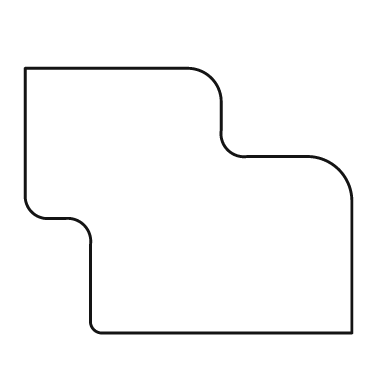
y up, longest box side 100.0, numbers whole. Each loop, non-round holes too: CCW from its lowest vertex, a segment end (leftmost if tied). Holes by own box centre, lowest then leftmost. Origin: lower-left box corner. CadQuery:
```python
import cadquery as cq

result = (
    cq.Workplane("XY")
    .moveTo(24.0, 0.0)
    .lineTo(100.0, 0.0)
    .lineTo(100.0, 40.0)
    .threePointArc((96.0, 50.0), (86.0, 54.0))
    .lineTo(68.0, 54.0)
    .threePointArc((62.0, 56.0), (60.0, 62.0))
    .lineTo(60.0, 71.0)
    .threePointArc((57.0, 78.0), (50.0, 81.0))
    .lineTo(0.0, 81.0)
    .lineTo(0.0, 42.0)
    .threePointArc((2.0, 37.0), (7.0, 35.0))
    .lineTo(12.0, 35.0)
    .threePointArc((18.0, 33.0), (20.0, 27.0))
    .lineTo(20.0, 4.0)
    .threePointArc((21.0, 1.0), (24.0, 0.0))
    .close()
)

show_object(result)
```